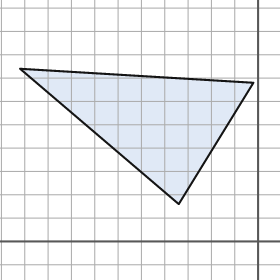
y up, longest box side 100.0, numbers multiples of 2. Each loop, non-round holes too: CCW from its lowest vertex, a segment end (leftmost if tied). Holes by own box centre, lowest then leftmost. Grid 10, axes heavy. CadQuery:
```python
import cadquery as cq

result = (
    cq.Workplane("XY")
    .moveTo(-34.0, 16.0)
    .lineTo(-2.0, 68.0)
    .lineTo(-102.0, 74.0)
    .close()
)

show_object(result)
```